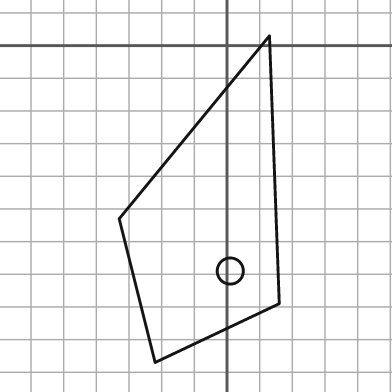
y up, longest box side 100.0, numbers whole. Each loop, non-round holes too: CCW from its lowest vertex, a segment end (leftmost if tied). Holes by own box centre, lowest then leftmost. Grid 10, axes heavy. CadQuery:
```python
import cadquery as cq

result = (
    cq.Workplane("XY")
    .moveTo(-22.0, -97.0)
    .lineTo(16.0, -79.0)
    .lineTo(13.0, 3.0)
    .lineTo(-33.0, -53.0)
    .close()
    .moveTo(1.0, -69.0)
    .circle(4.0)
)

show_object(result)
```